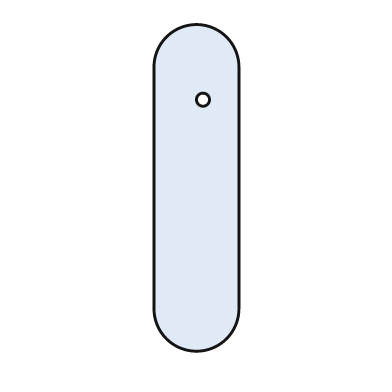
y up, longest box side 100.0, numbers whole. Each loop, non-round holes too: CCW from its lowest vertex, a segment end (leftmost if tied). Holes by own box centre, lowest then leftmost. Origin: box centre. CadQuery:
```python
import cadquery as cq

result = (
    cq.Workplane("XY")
    .moveTo(-13.0, -37.0)
    .threePointArc((0.0, -50.0), (13.0, -37.0))
    .lineTo(13.0, 37.0)
    .threePointArc((0.0, 50.0), (-13.0, 37.0))
    .close()
    .moveTo(2.0, 27.0)
    .circle(2.0)
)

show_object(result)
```